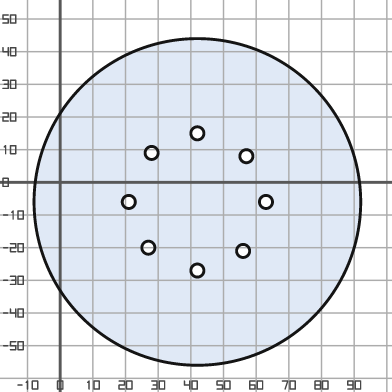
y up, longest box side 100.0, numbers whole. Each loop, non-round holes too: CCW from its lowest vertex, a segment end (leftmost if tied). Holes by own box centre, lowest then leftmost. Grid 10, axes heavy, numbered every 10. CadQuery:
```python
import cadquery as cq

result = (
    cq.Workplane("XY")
    .moveTo(42.0, -6.0)
    .circle(50.0)
    .moveTo(42.0, -27.0)
    .circle(2.0)
    .moveTo(56.0, -21.0)
    .circle(2.0)
    .moveTo(27.0, -20.0)
    .circle(2.0)
    .moveTo(21.0, -6.0)
    .circle(2.0)
    .moveTo(63.0, -6.0)
    .circle(2.0)
    .moveTo(57.0, 8.0)
    .circle(2.0)
    .moveTo(28.0, 9.0)
    .circle(2.0)
    .moveTo(42.0, 15.0)
    .circle(2.0)
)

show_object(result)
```